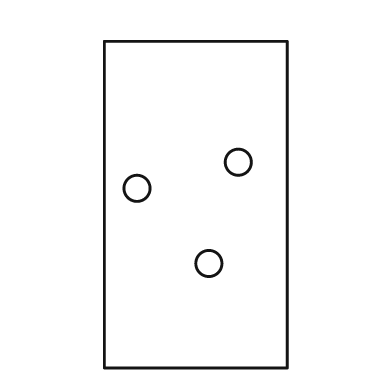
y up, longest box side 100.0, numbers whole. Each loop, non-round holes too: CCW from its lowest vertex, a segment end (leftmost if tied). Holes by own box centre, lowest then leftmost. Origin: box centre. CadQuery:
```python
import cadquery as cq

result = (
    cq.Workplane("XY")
    .moveTo(-28.0, -50.0)
    .lineTo(28.0, -50.0)
    .lineTo(28.0, 50.0)
    .lineTo(-28.0, 50.0)
    .close()
    .moveTo(4.0, -18.0)
    .circle(4.0)
    .moveTo(-18.0, 5.0)
    .circle(4.0)
    .moveTo(13.0, 13.0)
    .circle(4.0)
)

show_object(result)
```